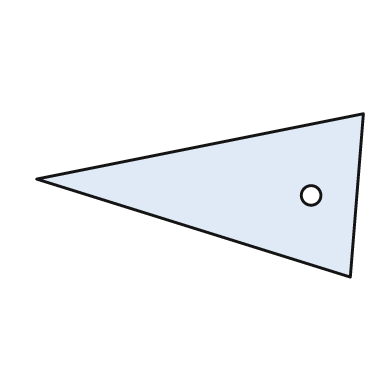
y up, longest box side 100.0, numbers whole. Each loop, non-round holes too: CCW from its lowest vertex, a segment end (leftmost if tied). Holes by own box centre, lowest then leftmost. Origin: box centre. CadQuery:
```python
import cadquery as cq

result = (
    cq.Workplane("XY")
    .moveTo(46.0, -25.0)
    .lineTo(50.0, 25.0)
    .lineTo(-50.0, 5.0)
    .close()
    .moveTo(34.0, 0.0)
    .circle(3.0)
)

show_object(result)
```